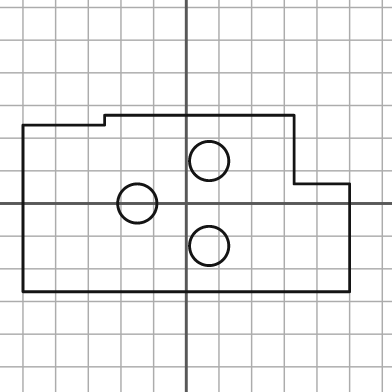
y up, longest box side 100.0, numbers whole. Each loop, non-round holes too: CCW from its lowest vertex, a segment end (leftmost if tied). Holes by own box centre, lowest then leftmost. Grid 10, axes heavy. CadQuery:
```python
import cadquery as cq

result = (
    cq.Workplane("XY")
    .moveTo(-50.0, -27.0)
    .lineTo(50.0, -27.0)
    .lineTo(50.0, 6.0)
    .lineTo(33.0, 6.0)
    .lineTo(33.0, 27.0)
    .lineTo(-25.0, 27.0)
    .lineTo(-25.0, 24.0)
    .lineTo(-50.0, 24.0)
    .close()
    .moveTo(7.0, -13.0)
    .circle(6.0)
    .moveTo(-15.0, 0.0)
    .circle(6.0)
    .moveTo(7.0, 13.0)
    .circle(6.0)
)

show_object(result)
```